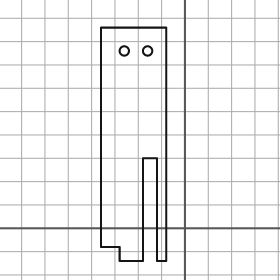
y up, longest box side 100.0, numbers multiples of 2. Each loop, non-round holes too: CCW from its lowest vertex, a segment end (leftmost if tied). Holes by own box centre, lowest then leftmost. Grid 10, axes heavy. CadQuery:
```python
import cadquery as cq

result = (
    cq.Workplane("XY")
    .moveTo(-28.0, -14.0)
    .lineTo(-18.0, -14.0)
    .lineTo(-18.0, 30.0)
    .lineTo(-12.0, 30.0)
    .lineTo(-12.0, -14.0)
    .lineTo(-8.0, -14.0)
    .lineTo(-8.0, 86.0)
    .lineTo(-36.0, 86.0)
    .lineTo(-36.0, -8.0)
    .lineTo(-28.0, -8.0)
    .close()
    .moveTo(-26.0, 76.0)
    .circle(2.0)
    .moveTo(-16.0, 76.0)
    .circle(2.0)
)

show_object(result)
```